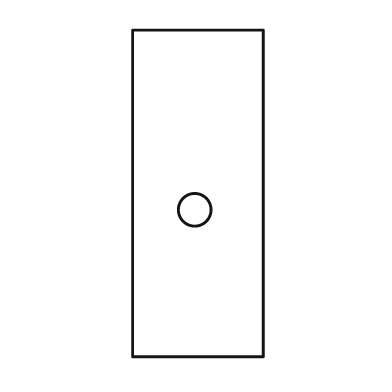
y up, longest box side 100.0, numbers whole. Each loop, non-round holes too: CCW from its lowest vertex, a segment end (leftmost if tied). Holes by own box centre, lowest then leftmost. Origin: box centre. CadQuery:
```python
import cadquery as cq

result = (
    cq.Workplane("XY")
    .moveTo(-20.0, -50.0)
    .lineTo(20.0, -50.0)
    .lineTo(20.0, 50.0)
    .lineTo(-20.0, 50.0)
    .close()
    .moveTo(-1.0, -5.0)
    .circle(5.0)
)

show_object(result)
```